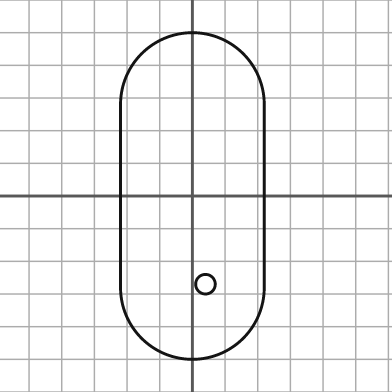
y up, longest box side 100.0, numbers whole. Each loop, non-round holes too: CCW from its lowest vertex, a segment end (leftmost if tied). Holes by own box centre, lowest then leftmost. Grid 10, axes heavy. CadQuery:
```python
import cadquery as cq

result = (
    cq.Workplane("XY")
    .moveTo(-22.0, -28.0)
    .threePointArc((0.0, -50.0), (22.0, -28.0))
    .lineTo(22.0, 28.0)
    .threePointArc((0.0, 50.0), (-22.0, 28.0))
    .close()
    .moveTo(4.0, -27.0)
    .circle(3.0)
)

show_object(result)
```